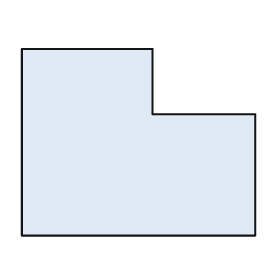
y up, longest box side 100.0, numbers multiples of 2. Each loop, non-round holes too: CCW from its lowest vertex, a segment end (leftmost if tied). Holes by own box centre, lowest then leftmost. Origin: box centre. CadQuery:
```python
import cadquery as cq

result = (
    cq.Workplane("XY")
    .moveTo(-50.0, -40.0)
    .lineTo(50.0, -40.0)
    .lineTo(50.0, 12.0)
    .lineTo(6.0, 12.0)
    .lineTo(6.0, 40.0)
    .lineTo(-50.0, 40.0)
    .close()
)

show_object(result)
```